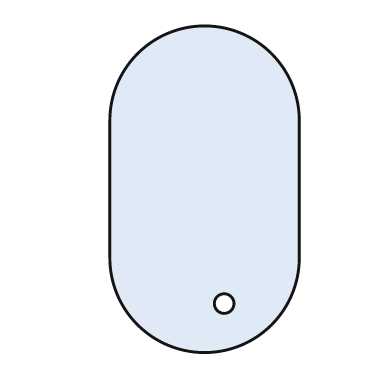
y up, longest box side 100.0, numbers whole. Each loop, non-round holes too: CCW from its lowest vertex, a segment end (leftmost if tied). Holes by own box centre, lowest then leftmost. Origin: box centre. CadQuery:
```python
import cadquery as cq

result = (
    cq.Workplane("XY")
    .moveTo(-29.0, -21.0)
    .threePointArc((0.0, -50.0), (29.0, -21.0))
    .lineTo(29.0, 21.0)
    .threePointArc((0.0, 50.0), (-29.0, 21.0))
    .close()
    .moveTo(6.0, -35.0)
    .circle(3.0)
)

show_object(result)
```